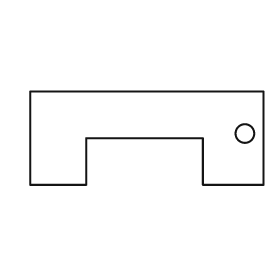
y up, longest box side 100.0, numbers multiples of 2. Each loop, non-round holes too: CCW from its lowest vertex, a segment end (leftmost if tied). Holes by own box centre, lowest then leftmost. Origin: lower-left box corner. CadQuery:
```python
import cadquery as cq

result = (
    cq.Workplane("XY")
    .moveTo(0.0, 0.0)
    .lineTo(24.0, 0.0)
    .lineTo(24.0, 20.0)
    .lineTo(74.0, 20.0)
    .lineTo(74.0, 0.0)
    .lineTo(100.0, 0.0)
    .lineTo(100.0, 40.0)
    .lineTo(0.0, 40.0)
    .close()
    .moveTo(92.0, 22.0)
    .circle(4.0)
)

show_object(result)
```